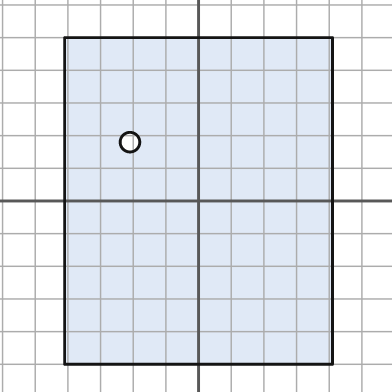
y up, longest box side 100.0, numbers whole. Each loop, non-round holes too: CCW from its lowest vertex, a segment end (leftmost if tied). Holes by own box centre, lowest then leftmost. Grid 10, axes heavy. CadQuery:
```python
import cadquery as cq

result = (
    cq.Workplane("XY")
    .moveTo(-41.0, -50.0)
    .lineTo(41.0, -50.0)
    .lineTo(41.0, 50.0)
    .lineTo(-41.0, 50.0)
    .close()
    .moveTo(-21.0, 18.0)
    .circle(3.0)
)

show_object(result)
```